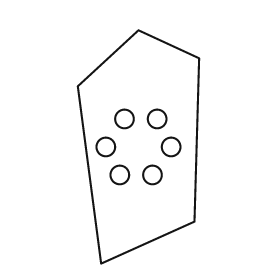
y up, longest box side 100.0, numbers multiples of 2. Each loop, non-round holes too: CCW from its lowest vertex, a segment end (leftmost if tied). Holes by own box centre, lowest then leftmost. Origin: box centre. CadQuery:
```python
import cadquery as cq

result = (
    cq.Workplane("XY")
    .moveTo(-16.0, -50.0)
    .lineTo(24.0, -32.0)
    .lineTo(26.0, 38.0)
    .lineTo(0.0, 50.0)
    .lineTo(-26.0, 26.0)
    .close()
    .moveTo(-8.0, -12.0)
    .circle(4.0)
    .moveTo(6.0, -12.0)
    .circle(4.0)
    .moveTo(-14.0, 0.0)
    .circle(4.0)
    .moveTo(14.0, 0.0)
    .circle(4.0)
    .moveTo(-6.0, 12.0)
    .circle(4.0)
    .moveTo(8.0, 12.0)
    .circle(4.0)
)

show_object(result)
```